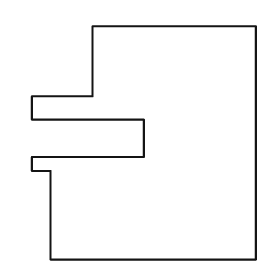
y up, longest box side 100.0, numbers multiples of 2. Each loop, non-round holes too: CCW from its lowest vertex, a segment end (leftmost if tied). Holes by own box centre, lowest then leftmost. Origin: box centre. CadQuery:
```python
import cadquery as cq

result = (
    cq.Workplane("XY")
    .moveTo(-40.0, -50.0)
    .lineTo(48.0, -50.0)
    .lineTo(48.0, 50.0)
    .lineTo(-22.0, 50.0)
    .lineTo(-22.0, 20.0)
    .lineTo(-48.0, 20.0)
    .lineTo(-48.0, 10.0)
    .lineTo(0.0, 10.0)
    .lineTo(0.0, -6.0)
    .lineTo(-48.0, -6.0)
    .lineTo(-48.0, -12.0)
    .lineTo(-40.0, -12.0)
    .close()
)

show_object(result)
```